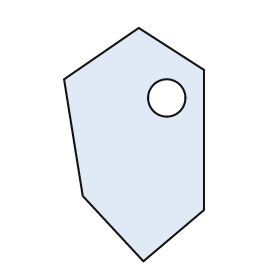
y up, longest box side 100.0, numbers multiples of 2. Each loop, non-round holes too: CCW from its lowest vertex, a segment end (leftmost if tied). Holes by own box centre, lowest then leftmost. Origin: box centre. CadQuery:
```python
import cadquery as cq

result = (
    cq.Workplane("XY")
    .moveTo(4.0, -50.0)
    .lineTo(30.0, -28.0)
    .lineTo(30.0, 32.0)
    .lineTo(2.0, 50.0)
    .lineTo(-30.0, 28.0)
    .lineTo(-22.0, -22.0)
    .close()
    .moveTo(14.0, 20.0)
    .circle(8.0)
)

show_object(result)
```